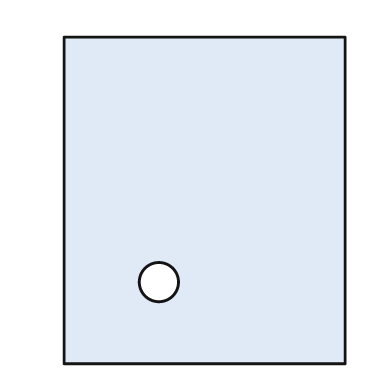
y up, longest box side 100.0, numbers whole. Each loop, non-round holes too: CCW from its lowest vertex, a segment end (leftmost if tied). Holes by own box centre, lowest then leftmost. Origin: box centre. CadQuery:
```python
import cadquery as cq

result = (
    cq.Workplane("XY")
    .moveTo(-43.0, -50.0)
    .lineTo(43.0, -50.0)
    .lineTo(43.0, 50.0)
    .lineTo(-43.0, 50.0)
    .close()
    .moveTo(-14.0, -25.0)
    .circle(6.0)
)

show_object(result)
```